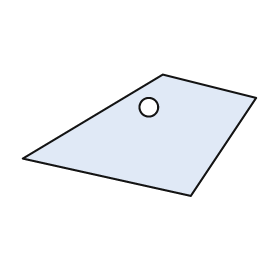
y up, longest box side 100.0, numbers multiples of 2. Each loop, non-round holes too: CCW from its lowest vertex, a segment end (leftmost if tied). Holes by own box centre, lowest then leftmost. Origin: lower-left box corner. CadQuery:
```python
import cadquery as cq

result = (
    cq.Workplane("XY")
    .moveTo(72.0, 0.0)
    .lineTo(100.0, 42.0)
    .lineTo(60.0, 52.0)
    .lineTo(0.0, 16.0)
    .close()
    .moveTo(54.0, 38.0)
    .circle(4.0)
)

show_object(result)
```